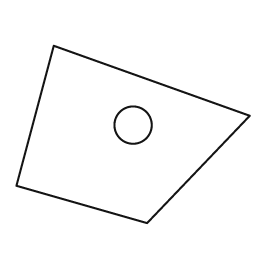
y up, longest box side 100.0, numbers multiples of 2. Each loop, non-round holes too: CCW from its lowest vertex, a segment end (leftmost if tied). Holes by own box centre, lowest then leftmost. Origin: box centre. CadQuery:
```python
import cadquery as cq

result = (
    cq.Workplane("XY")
    .moveTo(6.0, -38.0)
    .lineTo(50.0, 8.0)
    .lineTo(-34.0, 38.0)
    .lineTo(-50.0, -22.0)
    .close()
    .moveTo(0.0, 4.0)
    .circle(8.0)
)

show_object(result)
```